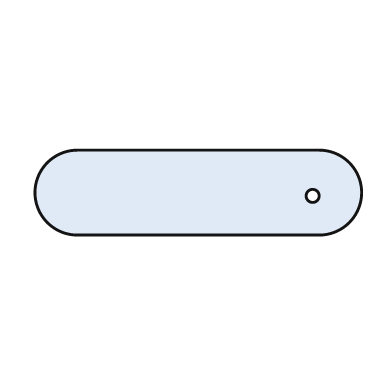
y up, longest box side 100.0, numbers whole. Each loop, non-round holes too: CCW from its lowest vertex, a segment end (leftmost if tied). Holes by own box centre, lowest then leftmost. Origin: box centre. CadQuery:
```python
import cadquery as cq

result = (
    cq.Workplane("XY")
    .moveTo(-37.0, -13.0)
    .lineTo(37.0, -13.0)
    .threePointArc((50.0, 0.0), (37.0, 13.0))
    .lineTo(-37.0, 13.0)
    .threePointArc((-50.0, 0.0), (-37.0, -13.0))
    .close()
    .moveTo(35.0, -1.0)
    .circle(2.0)
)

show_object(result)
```